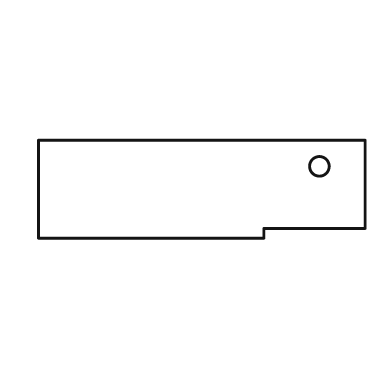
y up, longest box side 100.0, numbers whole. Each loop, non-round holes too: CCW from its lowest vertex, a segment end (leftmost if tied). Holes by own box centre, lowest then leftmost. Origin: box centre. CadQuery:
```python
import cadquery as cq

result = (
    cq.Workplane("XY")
    .moveTo(-50.0, -15.0)
    .lineTo(19.0, -15.0)
    .lineTo(19.0, -12.0)
    .lineTo(50.0, -12.0)
    .lineTo(50.0, 15.0)
    .lineTo(-50.0, 15.0)
    .close()
    .moveTo(36.0, 7.0)
    .circle(3.0)
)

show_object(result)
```